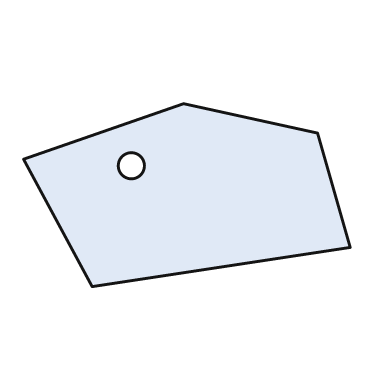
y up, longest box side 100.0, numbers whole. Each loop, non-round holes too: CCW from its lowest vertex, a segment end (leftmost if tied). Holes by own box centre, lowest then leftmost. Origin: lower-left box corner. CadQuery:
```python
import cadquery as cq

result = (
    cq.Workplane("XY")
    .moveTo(21.0, 0.0)
    .lineTo(100.0, 12.0)
    .lineTo(90.0, 47.0)
    .lineTo(49.0, 56.0)
    .lineTo(0.0, 39.0)
    .close()
    .moveTo(33.0, 37.0)
    .circle(4.0)
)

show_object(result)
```